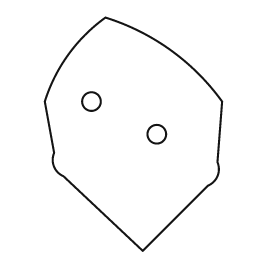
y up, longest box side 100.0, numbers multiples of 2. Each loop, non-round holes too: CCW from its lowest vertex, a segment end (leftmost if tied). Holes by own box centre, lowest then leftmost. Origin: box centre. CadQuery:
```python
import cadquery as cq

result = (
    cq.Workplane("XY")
    .moveTo(4.0, -50.0)
    .lineTo(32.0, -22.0)
    .threePointArc((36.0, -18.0), (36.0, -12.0))
    .lineTo(38.0, 14.0)
    .threePointArc((16.0, 36.0), (-12.0, 50.0))
    .threePointArc((-28.0, 34.0), (-38.0, 14.0))
    .lineTo(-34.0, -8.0)
    .threePointArc((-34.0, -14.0), (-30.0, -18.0))
    .close()
    .moveTo(10.0, 0.0)
    .circle(4.0)
    .moveTo(-18.0, 14.0)
    .circle(4.0)
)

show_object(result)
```